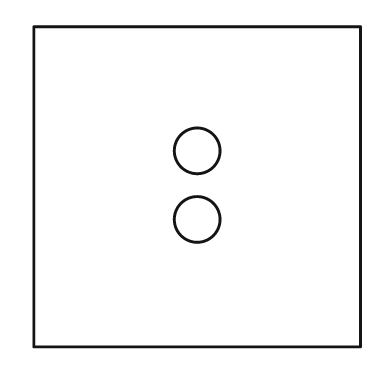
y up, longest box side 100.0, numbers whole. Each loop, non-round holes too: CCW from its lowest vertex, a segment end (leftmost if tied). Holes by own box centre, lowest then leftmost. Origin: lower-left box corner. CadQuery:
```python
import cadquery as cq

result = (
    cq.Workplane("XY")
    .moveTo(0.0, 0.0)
    .lineTo(100.0, 0.0)
    .lineTo(100.0, 98.0)
    .lineTo(0.0, 98.0)
    .close()
    .moveTo(50.0, 39.0)
    .circle(7.0)
    .moveTo(50.0, 60.0)
    .circle(7.0)
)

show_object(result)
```